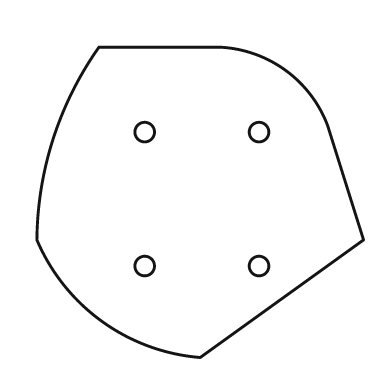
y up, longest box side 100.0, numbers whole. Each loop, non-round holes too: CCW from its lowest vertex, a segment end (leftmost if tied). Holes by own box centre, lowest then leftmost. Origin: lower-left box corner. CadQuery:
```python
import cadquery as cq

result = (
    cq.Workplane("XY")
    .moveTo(50.0, 0.0)
    .lineTo(100.0, 36.0)
    .lineTo(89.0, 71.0)
    .threePointArc((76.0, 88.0), (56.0, 95.0))
    .lineTo(19.0, 95.0)
    .threePointArc((5.0, 67.0), (0.0, 36.0))
    .threePointArc((20.0, 11.0), (50.0, 0.0))
    .close()
    .moveTo(33.0, 28.0)
    .circle(3.0)
    .moveTo(68.0, 28.0)
    .circle(3.0)
    .moveTo(33.0, 69.0)
    .circle(3.0)
    .moveTo(68.0, 69.0)
    .circle(3.0)
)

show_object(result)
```